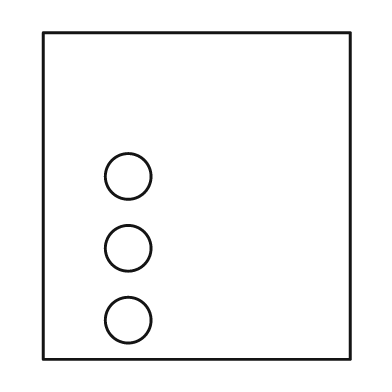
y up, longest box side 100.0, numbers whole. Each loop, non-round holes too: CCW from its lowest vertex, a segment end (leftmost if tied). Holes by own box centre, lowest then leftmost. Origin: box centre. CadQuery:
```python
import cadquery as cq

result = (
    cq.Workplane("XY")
    .moveTo(-47.0, -50.0)
    .lineTo(47.0, -50.0)
    .lineTo(47.0, 50.0)
    .lineTo(-47.0, 50.0)
    .close()
    .moveTo(-21.0, -38.0)
    .circle(7.0)
    .moveTo(-21.0, -16.0)
    .circle(7.0)
    .moveTo(-21.0, 6.0)
    .circle(7.0)
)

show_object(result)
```